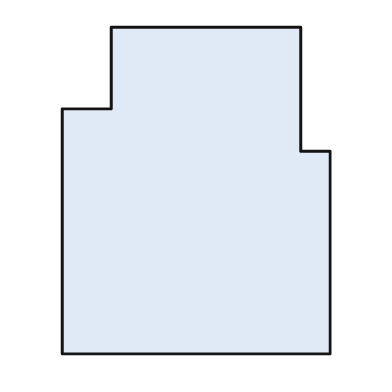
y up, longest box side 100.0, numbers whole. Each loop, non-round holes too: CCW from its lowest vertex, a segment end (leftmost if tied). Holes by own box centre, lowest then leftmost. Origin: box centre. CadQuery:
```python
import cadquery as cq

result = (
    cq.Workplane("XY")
    .moveTo(-41.0, -50.0)
    .lineTo(41.0, -50.0)
    .lineTo(41.0, 12.0)
    .lineTo(32.0, 12.0)
    .lineTo(32.0, 50.0)
    .lineTo(-26.0, 50.0)
    .lineTo(-26.0, 25.0)
    .lineTo(-41.0, 25.0)
    .close()
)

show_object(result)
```